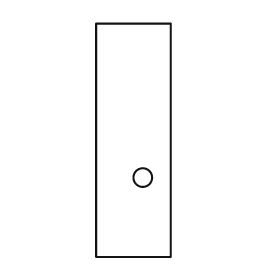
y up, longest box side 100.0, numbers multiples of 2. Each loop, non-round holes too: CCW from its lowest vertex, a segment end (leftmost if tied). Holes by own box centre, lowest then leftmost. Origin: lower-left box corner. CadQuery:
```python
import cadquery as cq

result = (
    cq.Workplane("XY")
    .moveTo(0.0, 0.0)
    .lineTo(32.0, 0.0)
    .lineTo(32.0, 100.0)
    .lineTo(0.0, 100.0)
    .close()
    .moveTo(20.0, 34.0)
    .circle(4.0)
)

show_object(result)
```